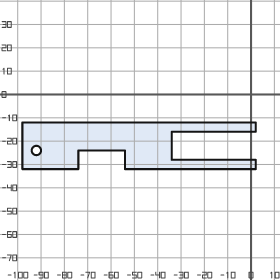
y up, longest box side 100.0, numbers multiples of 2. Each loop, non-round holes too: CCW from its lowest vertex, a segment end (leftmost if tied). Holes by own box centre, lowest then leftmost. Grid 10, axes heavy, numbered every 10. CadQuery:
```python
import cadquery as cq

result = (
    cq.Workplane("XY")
    .moveTo(-98.0, -32.0)
    .lineTo(-74.0, -32.0)
    .lineTo(-74.0, -24.0)
    .lineTo(-54.0, -24.0)
    .lineTo(-54.0, -32.0)
    .lineTo(2.0, -32.0)
    .lineTo(2.0, -28.0)
    .lineTo(-34.0, -28.0)
    .lineTo(-34.0, -16.0)
    .lineTo(2.0, -16.0)
    .lineTo(2.0, -12.0)
    .lineTo(-98.0, -12.0)
    .close()
    .moveTo(-92.0, -24.0)
    .circle(2.0)
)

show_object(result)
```